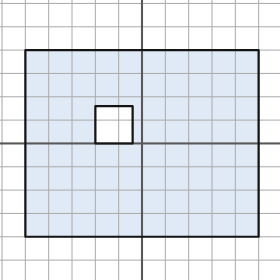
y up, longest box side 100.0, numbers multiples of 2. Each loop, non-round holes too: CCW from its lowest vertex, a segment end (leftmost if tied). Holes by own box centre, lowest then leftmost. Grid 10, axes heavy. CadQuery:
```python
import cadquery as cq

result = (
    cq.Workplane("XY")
    .moveTo(-50.0, -40.0)
    .lineTo(50.0, -40.0)
    .lineTo(50.0, 40.0)
    .lineTo(-50.0, 40.0)
    .close()
    .moveTo(-20.0, 0.0)
    .lineTo(-4.0, 0.0)
    .lineTo(-4.0, 16.0)
    .lineTo(-20.0, 16.0)
    .close()
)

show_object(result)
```